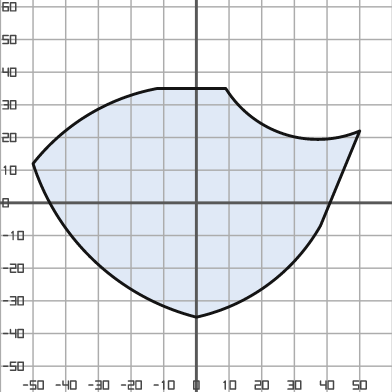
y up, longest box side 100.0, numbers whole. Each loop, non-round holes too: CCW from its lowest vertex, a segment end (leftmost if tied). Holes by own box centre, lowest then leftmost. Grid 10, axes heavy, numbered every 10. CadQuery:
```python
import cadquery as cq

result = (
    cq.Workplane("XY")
    .moveTo(0.0, -35.0)
    .threePointArc((22.0, -25.0), (38.0, -7.0))
    .lineTo(50.0, 22.0)
    .threePointArc((27.0, 21.0), (9.0, 35.0))
    .lineTo(-12.0, 35.0)
    .threePointArc((-33.0, 27.0), (-50.0, 12.0))
    .threePointArc((-31.0, -18.0), (0.0, -35.0))
    .close()
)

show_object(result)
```